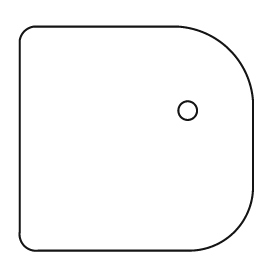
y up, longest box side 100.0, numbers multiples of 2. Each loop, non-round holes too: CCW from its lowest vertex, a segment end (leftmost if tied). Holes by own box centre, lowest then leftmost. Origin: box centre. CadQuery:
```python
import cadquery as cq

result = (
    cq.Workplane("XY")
    .moveTo(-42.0, -48.0)
    .lineTo(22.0, -48.0)
    .threePointArc((42.0, -40.0), (50.0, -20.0))
    .lineTo(50.0, 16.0)
    .threePointArc((40.0, 38.0), (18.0, 48.0))
    .lineTo(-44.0, 48.0)
    .threePointArc((-48.0, 46.0), (-50.0, 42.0))
    .lineTo(-50.0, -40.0)
    .threePointArc((-48.0, -46.0), (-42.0, -48.0))
    .close()
    .moveTo(22.0, 12.0)
    .circle(4.0)
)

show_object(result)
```